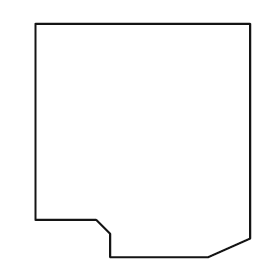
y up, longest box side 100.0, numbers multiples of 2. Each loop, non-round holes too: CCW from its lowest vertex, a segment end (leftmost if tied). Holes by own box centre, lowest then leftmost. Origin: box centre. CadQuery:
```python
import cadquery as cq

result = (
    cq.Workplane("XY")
    .moveTo(-14.0, -50.0)
    .lineTo(28.0, -50.0)
    .lineTo(46.0, -42.0)
    .lineTo(46.0, 50.0)
    .lineTo(-46.0, 50.0)
    .lineTo(-46.0, -34.0)
    .lineTo(-20.0, -34.0)
    .lineTo(-14.0, -40.0)
    .close()
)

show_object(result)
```